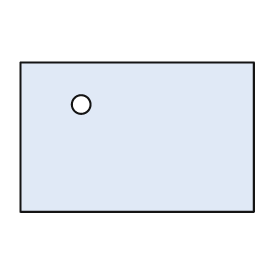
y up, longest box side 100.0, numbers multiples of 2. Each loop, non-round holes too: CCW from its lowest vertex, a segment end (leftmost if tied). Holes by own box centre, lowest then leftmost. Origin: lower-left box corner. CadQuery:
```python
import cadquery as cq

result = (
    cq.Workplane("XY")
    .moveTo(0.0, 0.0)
    .lineTo(100.0, 0.0)
    .lineTo(100.0, 64.0)
    .lineTo(0.0, 64.0)
    .close()
    .moveTo(26.0, 46.0)
    .circle(4.0)
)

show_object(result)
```